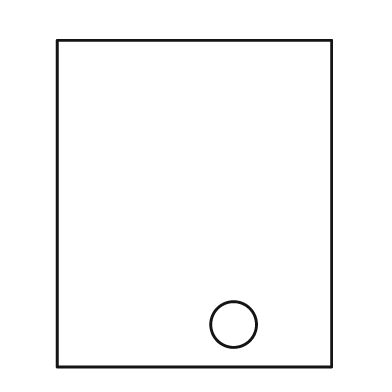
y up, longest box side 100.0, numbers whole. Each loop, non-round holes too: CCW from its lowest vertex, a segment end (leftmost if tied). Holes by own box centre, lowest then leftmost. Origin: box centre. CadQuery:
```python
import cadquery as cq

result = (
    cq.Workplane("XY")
    .moveTo(-42.0, -50.0)
    .lineTo(42.0, -50.0)
    .lineTo(42.0, 50.0)
    .lineTo(-42.0, 50.0)
    .close()
    .moveTo(12.0, -37.0)
    .circle(7.0)
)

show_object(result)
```